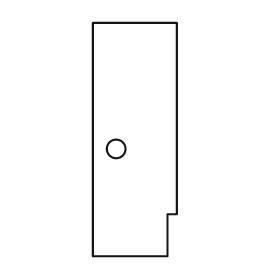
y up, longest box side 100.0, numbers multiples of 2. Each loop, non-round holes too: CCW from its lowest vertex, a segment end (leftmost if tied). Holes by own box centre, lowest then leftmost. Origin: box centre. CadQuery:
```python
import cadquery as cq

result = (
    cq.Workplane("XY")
    .moveTo(-18.0, -50.0)
    .lineTo(14.0, -50.0)
    .lineTo(14.0, -32.0)
    .lineTo(18.0, -32.0)
    .lineTo(18.0, 50.0)
    .lineTo(-18.0, 50.0)
    .close()
    .moveTo(-8.0, -4.0)
    .circle(4.0)
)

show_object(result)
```